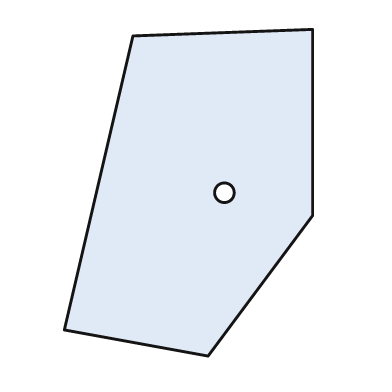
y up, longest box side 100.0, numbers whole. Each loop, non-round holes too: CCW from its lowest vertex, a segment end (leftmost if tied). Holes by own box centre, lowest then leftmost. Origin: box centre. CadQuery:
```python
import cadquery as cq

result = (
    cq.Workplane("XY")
    .moveTo(6.0, -50.0)
    .lineTo(38.0, -7.0)
    .lineTo(38.0, 50.0)
    .lineTo(-17.0, 48.0)
    .lineTo(-38.0, -42.0)
    .close()
    .moveTo(11.0, 0.0)
    .circle(3.0)
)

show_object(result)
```